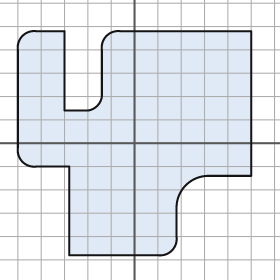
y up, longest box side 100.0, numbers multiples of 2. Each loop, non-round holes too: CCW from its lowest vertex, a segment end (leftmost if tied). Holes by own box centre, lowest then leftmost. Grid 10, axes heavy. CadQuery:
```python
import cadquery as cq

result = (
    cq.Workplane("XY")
    .moveTo(-28.0, -48.0)
    .lineTo(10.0, -48.0)
    .threePointArc((16.0, -46.0), (18.0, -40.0))
    .lineTo(18.0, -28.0)
    .threePointArc((22.0, -18.0), (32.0, -14.0))
    .lineTo(50.0, -14.0)
    .lineTo(50.0, 48.0)
    .lineTo(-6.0, 48.0)
    .threePointArc((-12.0, 46.0), (-14.0, 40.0))
    .lineTo(-14.0, 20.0)
    .threePointArc((-16.0, 16.0), (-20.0, 14.0))
    .lineTo(-30.0, 14.0)
    .lineTo(-30.0, 48.0)
    .lineTo(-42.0, 48.0)
    .threePointArc((-48.0, 46.0), (-50.0, 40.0))
    .lineTo(-50.0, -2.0)
    .threePointArc((-48.0, -8.0), (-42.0, -10.0))
    .lineTo(-28.0, -10.0)
    .close()
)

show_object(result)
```